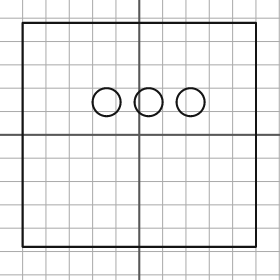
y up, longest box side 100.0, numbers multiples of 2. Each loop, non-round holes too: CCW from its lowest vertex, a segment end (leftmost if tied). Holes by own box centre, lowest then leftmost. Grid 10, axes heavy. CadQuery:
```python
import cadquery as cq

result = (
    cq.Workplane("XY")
    .moveTo(-50.0, -48.0)
    .lineTo(50.0, -48.0)
    .lineTo(50.0, 48.0)
    .lineTo(-50.0, 48.0)
    .close()
    .moveTo(-14.0, 14.0)
    .circle(6.0)
    .moveTo(4.0, 14.0)
    .circle(6.0)
    .moveTo(22.0, 14.0)
    .circle(6.0)
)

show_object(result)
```